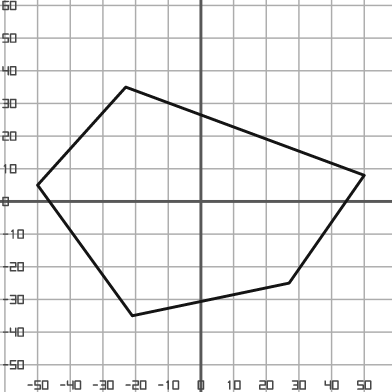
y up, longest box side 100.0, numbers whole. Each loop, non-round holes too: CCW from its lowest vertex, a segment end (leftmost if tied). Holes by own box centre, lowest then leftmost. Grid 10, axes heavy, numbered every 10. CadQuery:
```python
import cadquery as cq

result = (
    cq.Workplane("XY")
    .moveTo(-21.0, -35.0)
    .lineTo(27.0, -25.0)
    .lineTo(50.0, 8.0)
    .lineTo(-23.0, 35.0)
    .lineTo(-50.0, 5.0)
    .close()
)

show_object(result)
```